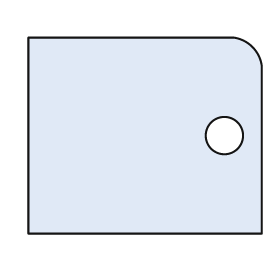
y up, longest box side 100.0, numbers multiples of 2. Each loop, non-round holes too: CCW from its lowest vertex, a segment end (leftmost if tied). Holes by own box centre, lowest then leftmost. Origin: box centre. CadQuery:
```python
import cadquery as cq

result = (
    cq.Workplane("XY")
    .moveTo(-50.0, -42.0)
    .lineTo(50.0, -42.0)
    .lineTo(50.0, 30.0)
    .threePointArc((46.0, 38.0), (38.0, 42.0))
    .lineTo(-50.0, 42.0)
    .close()
    .moveTo(34.0, 0.0)
    .circle(8.0)
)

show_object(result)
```